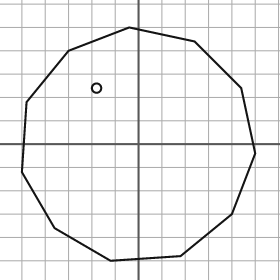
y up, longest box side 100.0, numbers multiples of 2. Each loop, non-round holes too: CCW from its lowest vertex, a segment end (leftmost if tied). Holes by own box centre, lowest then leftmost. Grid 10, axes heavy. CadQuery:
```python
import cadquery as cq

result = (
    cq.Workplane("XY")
    .moveTo(-12.0, -50.0)
    .lineTo(18.0, -48.0)
    .lineTo(40.0, -30.0)
    .lineTo(50.0, -4.0)
    .lineTo(44.0, 24.0)
    .lineTo(24.0, 44.0)
    .lineTo(-4.0, 50.0)
    .lineTo(-30.0, 40.0)
    .lineTo(-48.0, 18.0)
    .lineTo(-50.0, -12.0)
    .lineTo(-36.0, -36.0)
    .close()
    .moveTo(-18.0, 24.0)
    .circle(2.0)
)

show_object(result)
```